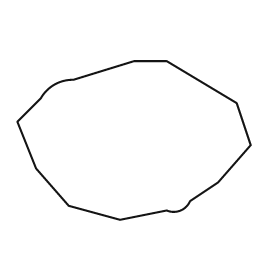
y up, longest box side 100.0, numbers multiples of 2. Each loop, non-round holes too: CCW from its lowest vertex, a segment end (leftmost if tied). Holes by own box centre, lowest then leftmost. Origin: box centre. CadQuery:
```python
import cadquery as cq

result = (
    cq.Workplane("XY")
    .moveTo(-6.0, -34.0)
    .lineTo(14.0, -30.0)
    .threePointArc((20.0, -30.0), (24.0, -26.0))
    .lineTo(36.0, -18.0)
    .lineTo(50.0, -2.0)
    .lineTo(44.0, 16.0)
    .lineTo(14.0, 34.0)
    .lineTo(0.0, 34.0)
    .lineTo(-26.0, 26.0)
    .threePointArc((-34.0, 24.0), (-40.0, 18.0))
    .lineTo(-50.0, 8.0)
    .lineTo(-42.0, -12.0)
    .lineTo(-28.0, -28.0)
    .close()
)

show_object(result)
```